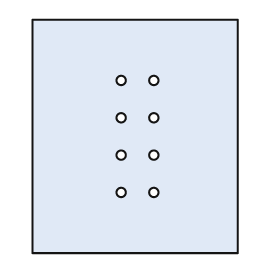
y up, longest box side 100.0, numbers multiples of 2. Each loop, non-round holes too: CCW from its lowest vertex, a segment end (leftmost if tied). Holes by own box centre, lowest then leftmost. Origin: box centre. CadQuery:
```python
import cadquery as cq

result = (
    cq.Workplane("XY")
    .moveTo(-44.0, -50.0)
    .lineTo(44.0, -50.0)
    .lineTo(44.0, 50.0)
    .lineTo(-44.0, 50.0)
    .close()
    .moveTo(-6.0, -24.0)
    .circle(2.0)
    .moveTo(8.0, -24.0)
    .circle(2.0)
    .moveTo(-6.0, -8.0)
    .circle(2.0)
    .moveTo(8.0, -8.0)
    .circle(2.0)
    .moveTo(-6.0, 8.0)
    .circle(2.0)
    .moveTo(8.0, 8.0)
    .circle(2.0)
    .moveTo(-6.0, 24.0)
    .circle(2.0)
    .moveTo(8.0, 24.0)
    .circle(2.0)
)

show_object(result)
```